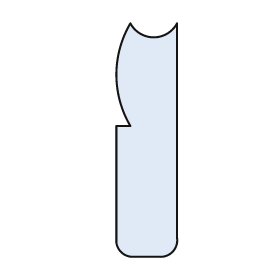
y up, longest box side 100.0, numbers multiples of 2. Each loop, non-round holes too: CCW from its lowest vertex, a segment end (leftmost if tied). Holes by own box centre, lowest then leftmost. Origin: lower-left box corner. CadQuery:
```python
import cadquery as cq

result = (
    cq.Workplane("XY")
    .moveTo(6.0, 0.0)
    .lineTo(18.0, 0.0)
    .threePointArc((24.0, 2.0), (26.0, 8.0))
    .lineTo(26.0, 100.0)
    .threePointArc((16.0, 94.0), (6.0, 100.0))
    .threePointArc((0.0, 78.0), (6.0, 56.0))
    .lineTo(0.0, 56.0)
    .lineTo(0.0, 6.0)
    .threePointArc((2.0, 2.0), (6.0, 0.0))
    .close()
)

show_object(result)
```